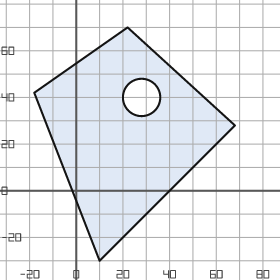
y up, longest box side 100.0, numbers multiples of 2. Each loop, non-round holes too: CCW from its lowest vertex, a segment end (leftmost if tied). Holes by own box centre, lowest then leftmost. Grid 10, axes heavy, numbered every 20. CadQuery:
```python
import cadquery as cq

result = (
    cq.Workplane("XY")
    .moveTo(10.0, -30.0)
    .lineTo(68.0, 28.0)
    .lineTo(22.0, 70.0)
    .lineTo(-18.0, 42.0)
    .close()
    .moveTo(28.0, 40.0)
    .circle(8.0)
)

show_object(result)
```